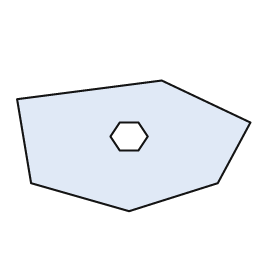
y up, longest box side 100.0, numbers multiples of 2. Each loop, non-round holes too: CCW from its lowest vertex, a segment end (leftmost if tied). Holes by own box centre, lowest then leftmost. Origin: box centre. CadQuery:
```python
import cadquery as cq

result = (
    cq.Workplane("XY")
    .moveTo(-2.0, -28.0)
    .lineTo(36.0, -16.0)
    .lineTo(50.0, 10.0)
    .lineTo(12.0, 28.0)
    .lineTo(-50.0, 20.0)
    .lineTo(-44.0, -16.0)
    .close()
    .moveTo(-6.0, -2.0)
    .lineTo(2.0, -2.0)
    .lineTo(6.0, 4.0)
    .lineTo(2.0, 10.0)
    .lineTo(-6.0, 10.0)
    .lineTo(-10.0, 4.0)
    .close()
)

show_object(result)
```